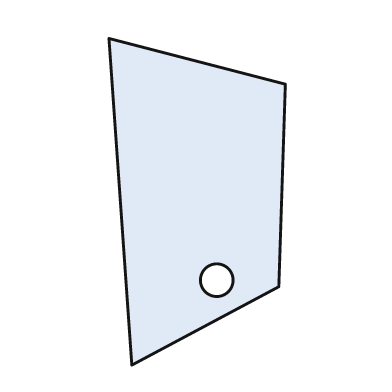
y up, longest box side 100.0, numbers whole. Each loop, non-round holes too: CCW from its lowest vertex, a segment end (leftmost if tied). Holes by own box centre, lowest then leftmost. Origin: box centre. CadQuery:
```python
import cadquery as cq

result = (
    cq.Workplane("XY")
    .moveTo(-20.0, -50.0)
    .lineTo(25.0, -26.0)
    .lineTo(27.0, 36.0)
    .lineTo(-27.0, 50.0)
    .close()
    .moveTo(6.0, -24.0)
    .circle(5.0)
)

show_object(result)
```